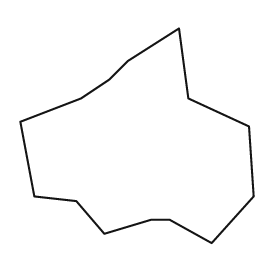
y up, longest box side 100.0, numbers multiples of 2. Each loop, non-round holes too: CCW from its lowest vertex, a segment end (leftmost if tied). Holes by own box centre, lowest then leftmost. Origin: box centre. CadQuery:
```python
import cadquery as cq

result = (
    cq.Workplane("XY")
    .moveTo(32.0, -46.0)
    .lineTo(50.0, -26.0)
    .lineTo(48.0, 4.0)
    .lineTo(22.0, 16.0)
    .lineTo(18.0, 46.0)
    .lineTo(-4.0, 32.0)
    .lineTo(-12.0, 24.0)
    .lineTo(-24.0, 16.0)
    .lineTo(-50.0, 6.0)
    .lineTo(-44.0, -26.0)
    .lineTo(-26.0, -28.0)
    .lineTo(-14.0, -42.0)
    .lineTo(6.0, -36.0)
    .lineTo(14.0, -36.0)
    .close()
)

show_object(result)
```